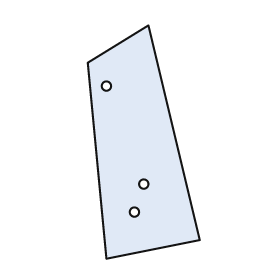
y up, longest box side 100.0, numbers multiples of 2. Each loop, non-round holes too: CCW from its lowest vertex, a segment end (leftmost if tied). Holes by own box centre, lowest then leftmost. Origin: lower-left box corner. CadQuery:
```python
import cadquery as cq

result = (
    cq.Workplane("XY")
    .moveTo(8.0, 0.0)
    .lineTo(48.0, 8.0)
    .lineTo(26.0, 100.0)
    .lineTo(0.0, 84.0)
    .close()
    .moveTo(20.0, 20.0)
    .circle(2.0)
    .moveTo(24.0, 32.0)
    .circle(2.0)
    .moveTo(8.0, 74.0)
    .circle(2.0)
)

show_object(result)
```